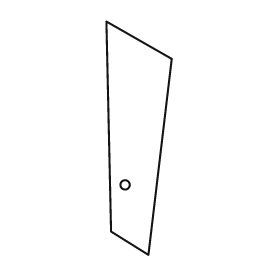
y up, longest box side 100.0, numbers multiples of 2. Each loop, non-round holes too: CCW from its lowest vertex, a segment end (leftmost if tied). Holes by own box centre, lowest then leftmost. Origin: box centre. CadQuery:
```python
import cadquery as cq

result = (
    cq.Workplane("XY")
    .moveTo(4.0, -50.0)
    .lineTo(14.0, 34.0)
    .lineTo(-14.0, 50.0)
    .lineTo(-12.0, -40.0)
    .close()
    .moveTo(-6.0, -20.0)
    .circle(2.0)
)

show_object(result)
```